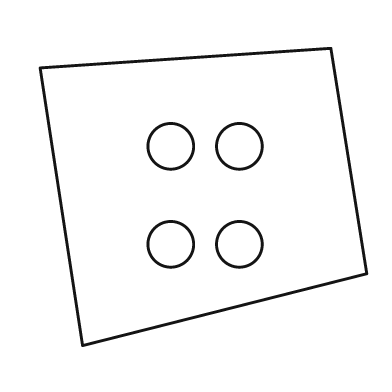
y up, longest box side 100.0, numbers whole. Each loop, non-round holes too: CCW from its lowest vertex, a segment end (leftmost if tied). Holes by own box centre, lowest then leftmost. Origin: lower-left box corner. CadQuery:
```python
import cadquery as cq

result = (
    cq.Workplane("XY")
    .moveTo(13.0, 0.0)
    .lineTo(100.0, 22.0)
    .lineTo(89.0, 91.0)
    .lineTo(0.0, 85.0)
    .close()
    .moveTo(40.0, 31.0)
    .circle(7.0)
    .moveTo(61.0, 31.0)
    .circle(7.0)
    .moveTo(40.0, 61.0)
    .circle(7.0)
    .moveTo(61.0, 61.0)
    .circle(7.0)
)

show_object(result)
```